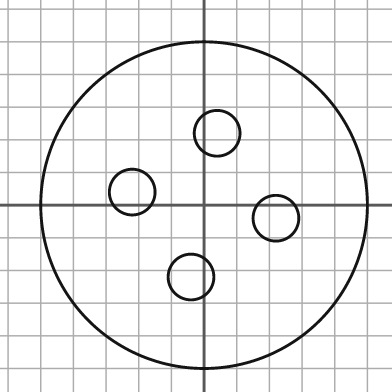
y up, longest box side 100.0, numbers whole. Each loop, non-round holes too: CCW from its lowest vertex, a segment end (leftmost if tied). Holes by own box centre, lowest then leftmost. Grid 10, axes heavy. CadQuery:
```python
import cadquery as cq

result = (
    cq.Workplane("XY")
    .moveTo(0.0, 0.0)
    .circle(50.0)
    .moveTo(-4.0, -22.0)
    .circle(7.0)
    .moveTo(22.0, -4.0)
    .circle(7.0)
    .moveTo(-22.0, 4.0)
    .circle(7.0)
    .moveTo(4.0, 22.0)
    .circle(7.0)
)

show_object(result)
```